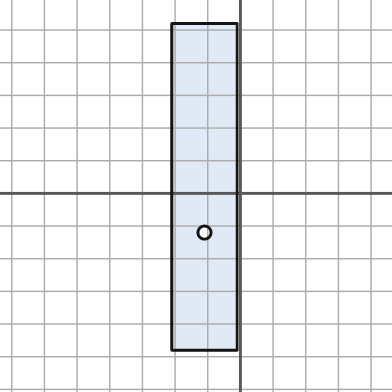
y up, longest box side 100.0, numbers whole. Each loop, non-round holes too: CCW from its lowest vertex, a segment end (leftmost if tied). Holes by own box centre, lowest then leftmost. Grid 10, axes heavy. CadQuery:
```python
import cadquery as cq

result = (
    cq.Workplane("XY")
    .moveTo(-21.0, -48.0)
    .lineTo(-1.0, -48.0)
    .lineTo(-1.0, 52.0)
    .lineTo(-21.0, 52.0)
    .close()
    .moveTo(-11.0, -12.0)
    .circle(2.0)
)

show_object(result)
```